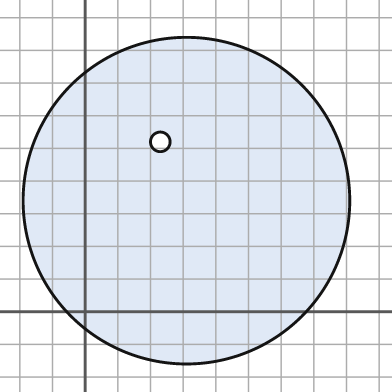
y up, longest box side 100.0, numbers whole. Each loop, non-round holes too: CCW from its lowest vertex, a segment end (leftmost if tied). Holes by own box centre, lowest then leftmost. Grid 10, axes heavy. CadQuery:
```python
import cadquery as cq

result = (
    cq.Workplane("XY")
    .moveTo(31.0, 34.0)
    .circle(50.0)
    .moveTo(23.0, 52.0)
    .circle(3.0)
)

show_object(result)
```